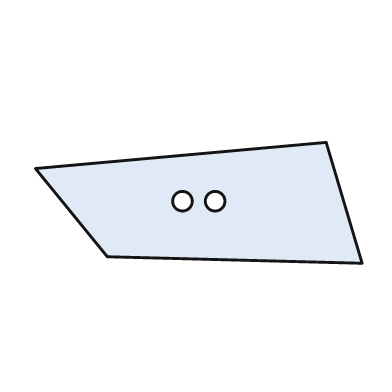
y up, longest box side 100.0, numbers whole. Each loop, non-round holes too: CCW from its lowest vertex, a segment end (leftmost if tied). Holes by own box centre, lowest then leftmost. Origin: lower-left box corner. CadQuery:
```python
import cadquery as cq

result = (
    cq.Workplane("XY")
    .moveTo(100.0, 0.0)
    .lineTo(89.0, 37.0)
    .lineTo(0.0, 29.0)
    .lineTo(22.0, 2.0)
    .close()
    .moveTo(45.0, 19.0)
    .circle(3.0)
    .moveTo(55.0, 19.0)
    .circle(3.0)
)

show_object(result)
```